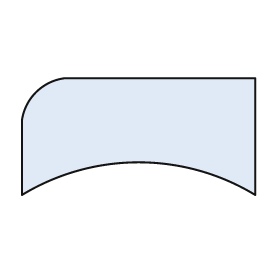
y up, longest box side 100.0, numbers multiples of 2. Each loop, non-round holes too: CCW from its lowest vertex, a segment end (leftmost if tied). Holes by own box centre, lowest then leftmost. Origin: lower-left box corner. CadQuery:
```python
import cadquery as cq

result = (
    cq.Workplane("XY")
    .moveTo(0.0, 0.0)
    .threePointArc((50.0, 14.0), (100.0, 0.0))
    .lineTo(100.0, 50.0)
    .lineTo(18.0, 50.0)
    .threePointArc((6.0, 44.0), (0.0, 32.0))
    .close()
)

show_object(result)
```